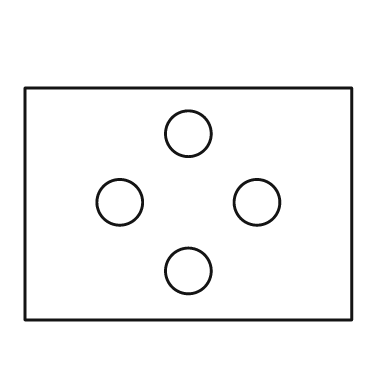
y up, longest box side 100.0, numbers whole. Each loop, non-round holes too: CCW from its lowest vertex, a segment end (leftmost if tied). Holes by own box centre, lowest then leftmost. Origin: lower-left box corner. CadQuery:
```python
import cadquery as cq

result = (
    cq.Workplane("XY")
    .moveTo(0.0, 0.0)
    .lineTo(100.0, 0.0)
    .lineTo(100.0, 71.0)
    .lineTo(0.0, 71.0)
    .close()
    .moveTo(50.0, 15.0)
    .circle(7.0)
    .moveTo(29.0, 36.0)
    .circle(7.0)
    .moveTo(71.0, 36.0)
    .circle(7.0)
    .moveTo(50.0, 57.0)
    .circle(7.0)
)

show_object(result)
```